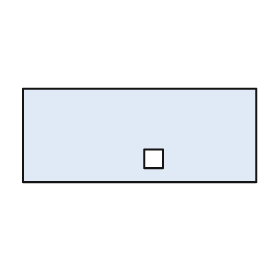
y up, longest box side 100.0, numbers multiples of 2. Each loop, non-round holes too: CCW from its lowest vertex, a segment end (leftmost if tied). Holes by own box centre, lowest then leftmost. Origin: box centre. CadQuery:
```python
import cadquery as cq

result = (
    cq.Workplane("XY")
    .moveTo(-50.0, -20.0)
    .lineTo(50.0, -20.0)
    .lineTo(50.0, 20.0)
    .lineTo(-50.0, 20.0)
    .close()
    .moveTo(2.0, -14.0)
    .lineTo(10.0, -14.0)
    .lineTo(10.0, -6.0)
    .lineTo(2.0, -6.0)
    .close()
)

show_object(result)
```